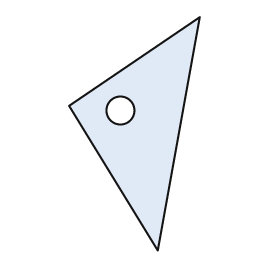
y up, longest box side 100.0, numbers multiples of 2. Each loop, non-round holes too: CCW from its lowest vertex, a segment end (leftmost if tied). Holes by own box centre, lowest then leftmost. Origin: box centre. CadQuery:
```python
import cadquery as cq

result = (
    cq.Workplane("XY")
    .moveTo(10.0, -50.0)
    .lineTo(28.0, 50.0)
    .lineTo(-28.0, 12.0)
    .close()
    .moveTo(-6.0, 10.0)
    .circle(6.0)
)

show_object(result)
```